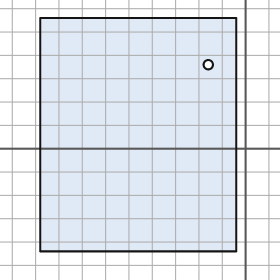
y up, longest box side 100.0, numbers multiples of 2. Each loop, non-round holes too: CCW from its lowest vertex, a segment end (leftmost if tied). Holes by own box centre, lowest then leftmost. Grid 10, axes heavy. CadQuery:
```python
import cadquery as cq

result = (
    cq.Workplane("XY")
    .moveTo(-88.0, -44.0)
    .lineTo(-4.0, -44.0)
    .lineTo(-4.0, 56.0)
    .lineTo(-88.0, 56.0)
    .close()
    .moveTo(-16.0, 36.0)
    .circle(2.0)
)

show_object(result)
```